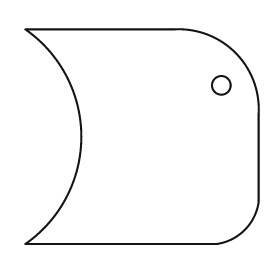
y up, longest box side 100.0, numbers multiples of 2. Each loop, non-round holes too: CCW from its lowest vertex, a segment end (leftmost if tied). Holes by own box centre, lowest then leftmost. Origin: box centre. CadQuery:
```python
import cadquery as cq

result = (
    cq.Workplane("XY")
    .moveTo(-50.0, -46.0)
    .lineTo(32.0, -46.0)
    .threePointArc((44.0, -40.0), (50.0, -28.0))
    .lineTo(50.0, 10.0)
    .threePointArc((40.0, 36.0), (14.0, 46.0))
    .lineTo(-50.0, 46.0)
    .threePointArc((-26.0, 0.0), (-50.0, -46.0))
    .close()
    .moveTo(34.0, 22.0)
    .circle(4.0)
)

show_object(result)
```